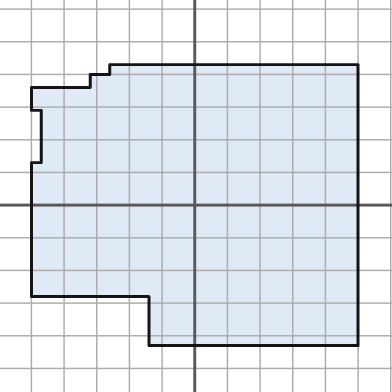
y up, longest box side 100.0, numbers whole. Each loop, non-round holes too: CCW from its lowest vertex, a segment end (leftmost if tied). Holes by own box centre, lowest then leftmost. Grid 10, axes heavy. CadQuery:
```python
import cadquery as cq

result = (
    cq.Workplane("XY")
    .moveTo(-14.0, -43.0)
    .lineTo(50.0, -43.0)
    .lineTo(50.0, 43.0)
    .lineTo(-26.0, 43.0)
    .lineTo(-26.0, 40.0)
    .lineTo(-32.0, 40.0)
    .lineTo(-32.0, 36.0)
    .lineTo(-50.0, 36.0)
    .lineTo(-50.0, 29.0)
    .lineTo(-47.0, 29.0)
    .lineTo(-47.0, 13.0)
    .lineTo(-50.0, 13.0)
    .lineTo(-50.0, -28.0)
    .lineTo(-14.0, -28.0)
    .close()
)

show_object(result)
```